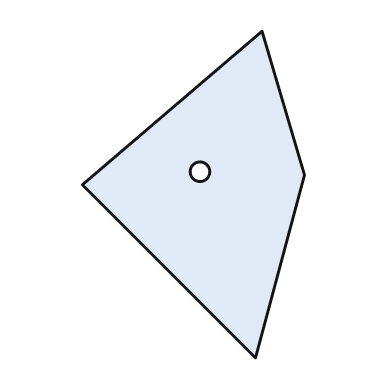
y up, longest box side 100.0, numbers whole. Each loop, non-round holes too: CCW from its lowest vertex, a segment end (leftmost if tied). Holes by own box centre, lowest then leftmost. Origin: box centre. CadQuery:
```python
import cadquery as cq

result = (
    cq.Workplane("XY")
    .moveTo(19.0, -50.0)
    .lineTo(34.0, 6.0)
    .lineTo(21.0, 50.0)
    .lineTo(-34.0, 3.0)
    .close()
    .moveTo(2.0, 7.0)
    .circle(3.0)
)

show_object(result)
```